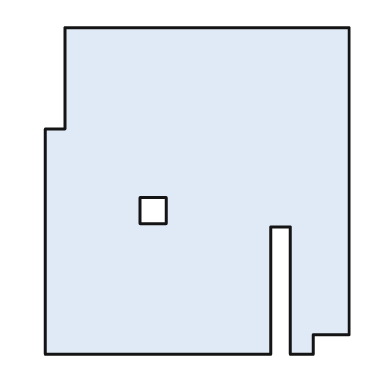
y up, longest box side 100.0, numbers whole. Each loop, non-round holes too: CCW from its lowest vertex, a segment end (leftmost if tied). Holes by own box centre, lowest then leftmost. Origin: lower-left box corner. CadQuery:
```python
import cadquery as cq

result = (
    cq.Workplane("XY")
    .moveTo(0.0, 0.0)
    .lineTo(69.0, 0.0)
    .lineTo(69.0, 39.0)
    .lineTo(75.0, 39.0)
    .lineTo(75.0, 0.0)
    .lineTo(82.0, 0.0)
    .lineTo(82.0, 6.0)
    .lineTo(93.0, 6.0)
    .lineTo(93.0, 100.0)
    .lineTo(6.0, 100.0)
    .lineTo(6.0, 69.0)
    .lineTo(0.0, 69.0)
    .close()
    .moveTo(29.0, 40.0)
    .lineTo(37.0, 40.0)
    .lineTo(37.0, 48.0)
    .lineTo(29.0, 48.0)
    .close()
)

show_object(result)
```